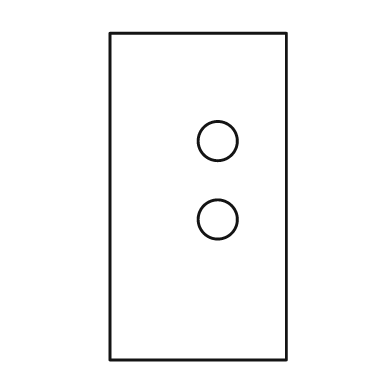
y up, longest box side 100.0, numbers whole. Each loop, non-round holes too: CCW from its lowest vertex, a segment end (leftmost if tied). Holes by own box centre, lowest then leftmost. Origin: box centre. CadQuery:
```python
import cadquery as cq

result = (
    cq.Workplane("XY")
    .moveTo(-27.0, -50.0)
    .lineTo(27.0, -50.0)
    .lineTo(27.0, 50.0)
    .lineTo(-27.0, 50.0)
    .close()
    .moveTo(6.0, -7.0)
    .circle(6.0)
    .moveTo(6.0, 17.0)
    .circle(6.0)
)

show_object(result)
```